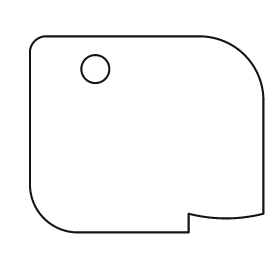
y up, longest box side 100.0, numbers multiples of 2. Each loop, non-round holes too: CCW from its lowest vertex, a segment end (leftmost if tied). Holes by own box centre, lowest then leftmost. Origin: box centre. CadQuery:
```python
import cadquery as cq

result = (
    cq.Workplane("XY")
    .moveTo(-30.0, -42.0)
    .lineTo(18.0, -42.0)
    .lineTo(18.0, -34.0)
    .threePointArc((34.0, -36.0), (50.0, -34.0))
    .lineTo(50.0, 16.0)
    .threePointArc((42.0, 34.0), (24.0, 42.0))
    .lineTo(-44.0, 42.0)
    .threePointArc((-48.0, 40.0), (-50.0, 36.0))
    .lineTo(-50.0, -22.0)
    .threePointArc((-44.0, -36.0), (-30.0, -42.0))
    .close()
    .moveTo(-22.0, 28.0)
    .circle(6.0)
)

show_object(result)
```